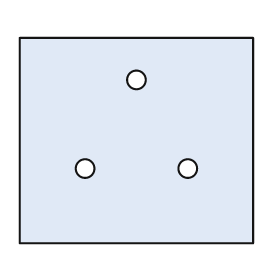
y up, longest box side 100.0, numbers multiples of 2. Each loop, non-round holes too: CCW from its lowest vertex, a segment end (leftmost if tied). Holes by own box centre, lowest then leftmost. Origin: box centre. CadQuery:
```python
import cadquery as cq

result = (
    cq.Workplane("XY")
    .moveTo(-50.0, -44.0)
    .lineTo(50.0, -44.0)
    .lineTo(50.0, 44.0)
    .lineTo(-50.0, 44.0)
    .close()
    .moveTo(-22.0, -12.0)
    .circle(4.0)
    .moveTo(22.0, -12.0)
    .circle(4.0)
    .moveTo(0.0, 26.0)
    .circle(4.0)
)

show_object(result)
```